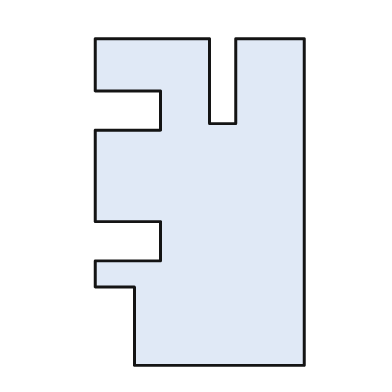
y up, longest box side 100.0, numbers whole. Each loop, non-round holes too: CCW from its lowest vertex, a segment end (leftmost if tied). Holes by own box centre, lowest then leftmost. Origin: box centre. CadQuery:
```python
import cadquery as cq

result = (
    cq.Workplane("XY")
    .moveTo(-20.0, -50.0)
    .lineTo(32.0, -50.0)
    .lineTo(32.0, 50.0)
    .lineTo(11.0, 50.0)
    .lineTo(11.0, 24.0)
    .lineTo(3.0, 24.0)
    .lineTo(3.0, 50.0)
    .lineTo(-32.0, 50.0)
    .lineTo(-32.0, 34.0)
    .lineTo(-12.0, 34.0)
    .lineTo(-12.0, 22.0)
    .lineTo(-32.0, 22.0)
    .lineTo(-32.0, -6.0)
    .lineTo(-12.0, -6.0)
    .lineTo(-12.0, -18.0)
    .lineTo(-32.0, -18.0)
    .lineTo(-32.0, -26.0)
    .lineTo(-20.0, -26.0)
    .close()
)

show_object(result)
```